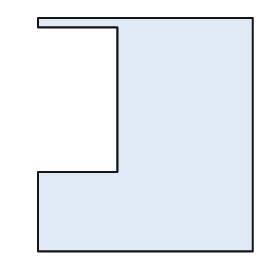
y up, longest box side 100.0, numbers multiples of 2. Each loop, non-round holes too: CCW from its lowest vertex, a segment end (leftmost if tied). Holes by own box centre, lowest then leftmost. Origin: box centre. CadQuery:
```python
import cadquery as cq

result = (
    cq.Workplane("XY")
    .moveTo(-46.0, -50.0)
    .lineTo(46.0, -50.0)
    .lineTo(46.0, 50.0)
    .lineTo(-46.0, 50.0)
    .lineTo(-46.0, 46.0)
    .lineTo(-12.0, 46.0)
    .lineTo(-12.0, -16.0)
    .lineTo(-46.0, -16.0)
    .close()
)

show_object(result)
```